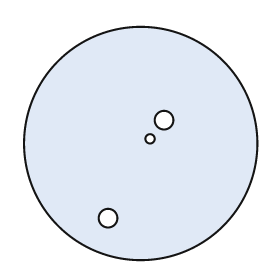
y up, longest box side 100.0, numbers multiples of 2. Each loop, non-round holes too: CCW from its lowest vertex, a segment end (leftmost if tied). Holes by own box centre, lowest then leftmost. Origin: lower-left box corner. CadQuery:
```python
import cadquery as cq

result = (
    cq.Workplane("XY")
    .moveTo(50.0, 50.0)
    .circle(50.0)
    .moveTo(36.0, 18.0)
    .circle(4.0)
    .moveTo(54.0, 52.0)
    .circle(2.0)
    .moveTo(60.0, 60.0)
    .circle(4.0)
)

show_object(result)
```